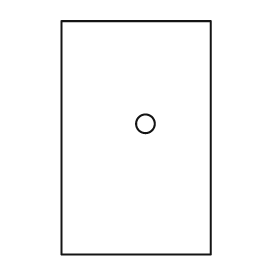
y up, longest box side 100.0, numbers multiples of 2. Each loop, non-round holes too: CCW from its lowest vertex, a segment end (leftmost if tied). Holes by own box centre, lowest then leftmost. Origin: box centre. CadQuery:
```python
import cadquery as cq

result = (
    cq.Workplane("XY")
    .moveTo(-32.0, -50.0)
    .lineTo(32.0, -50.0)
    .lineTo(32.0, 50.0)
    .lineTo(-32.0, 50.0)
    .close()
    .moveTo(4.0, 6.0)
    .circle(4.0)
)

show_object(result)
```